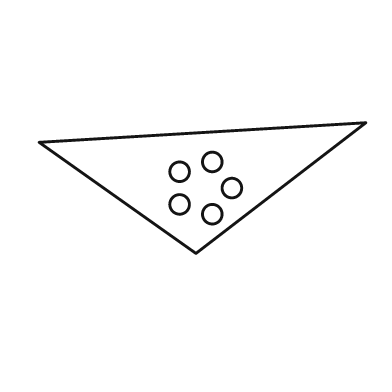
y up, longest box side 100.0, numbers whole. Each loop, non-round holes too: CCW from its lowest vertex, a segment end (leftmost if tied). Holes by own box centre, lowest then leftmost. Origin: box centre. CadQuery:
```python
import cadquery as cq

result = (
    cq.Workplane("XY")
    .moveTo(-2.0, -20.0)
    .lineTo(50.0, 20.0)
    .lineTo(-50.0, 14.0)
    .close()
    .moveTo(3.0, -8.0)
    .circle(3.0)
    .moveTo(-7.0, -5.0)
    .circle(3.0)
    .moveTo(9.0, 0.0)
    .circle(3.0)
    .moveTo(-7.0, 5.0)
    .circle(3.0)
    .moveTo(3.0, 8.0)
    .circle(3.0)
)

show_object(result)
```